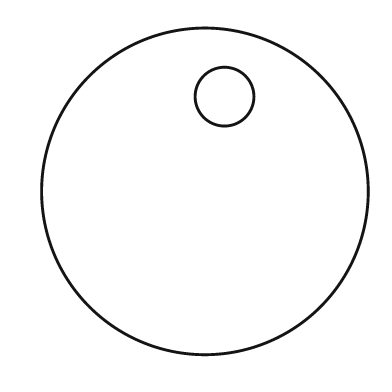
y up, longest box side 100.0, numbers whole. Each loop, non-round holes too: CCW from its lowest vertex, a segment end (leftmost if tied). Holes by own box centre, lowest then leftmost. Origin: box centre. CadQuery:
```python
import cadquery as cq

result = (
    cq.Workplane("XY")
    .moveTo(0.0, 0.0)
    .circle(50.0)
    .moveTo(6.0, 29.0)
    .circle(9.0)
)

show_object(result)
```